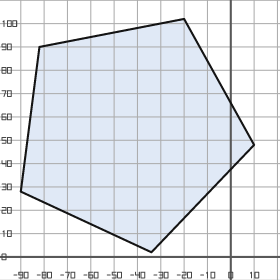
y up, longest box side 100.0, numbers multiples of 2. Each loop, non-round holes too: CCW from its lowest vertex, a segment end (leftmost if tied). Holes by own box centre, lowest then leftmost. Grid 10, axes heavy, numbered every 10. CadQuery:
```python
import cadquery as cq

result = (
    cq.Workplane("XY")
    .moveTo(-34.0, 2.0)
    .lineTo(10.0, 48.0)
    .lineTo(-20.0, 102.0)
    .lineTo(-82.0, 90.0)
    .lineTo(-90.0, 28.0)
    .close()
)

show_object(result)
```